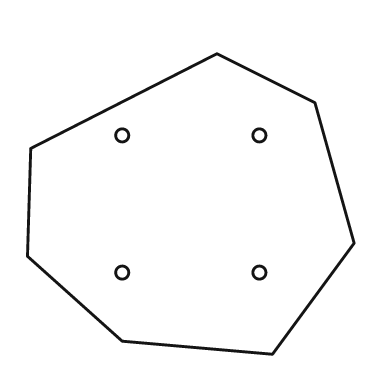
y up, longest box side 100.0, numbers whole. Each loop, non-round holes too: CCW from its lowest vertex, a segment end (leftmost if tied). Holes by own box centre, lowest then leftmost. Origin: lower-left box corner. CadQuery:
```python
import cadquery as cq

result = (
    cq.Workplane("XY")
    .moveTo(75.0, 0.0)
    .lineTo(100.0, 34.0)
    .lineTo(88.0, 77.0)
    .lineTo(58.0, 92.0)
    .lineTo(1.0, 63.0)
    .lineTo(0.0, 30.0)
    .lineTo(29.0, 4.0)
    .close()
    .moveTo(29.0, 25.0)
    .circle(2.0)
    .moveTo(71.0, 25.0)
    .circle(2.0)
    .moveTo(29.0, 67.0)
    .circle(2.0)
    .moveTo(71.0, 67.0)
    .circle(2.0)
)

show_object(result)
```